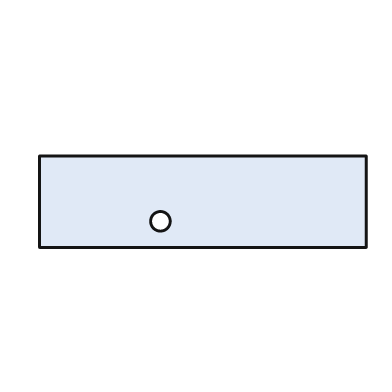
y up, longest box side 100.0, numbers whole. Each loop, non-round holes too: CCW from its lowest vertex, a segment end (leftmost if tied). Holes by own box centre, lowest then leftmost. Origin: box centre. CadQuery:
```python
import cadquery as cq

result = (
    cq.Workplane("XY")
    .moveTo(-50.0, -14.0)
    .lineTo(50.0, -14.0)
    .lineTo(50.0, 14.0)
    .lineTo(-50.0, 14.0)
    .close()
    .moveTo(-13.0, -6.0)
    .circle(3.0)
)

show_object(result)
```